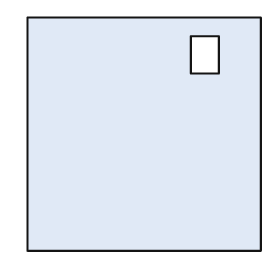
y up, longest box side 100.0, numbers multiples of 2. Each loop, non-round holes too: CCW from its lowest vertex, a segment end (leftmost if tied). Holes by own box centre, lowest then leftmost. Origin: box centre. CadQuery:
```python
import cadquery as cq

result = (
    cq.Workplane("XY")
    .moveTo(-50.0, -50.0)
    .lineTo(50.0, -50.0)
    .lineTo(50.0, 50.0)
    .lineTo(-50.0, 50.0)
    .close()
    .moveTo(20.0, 26.0)
    .lineTo(32.0, 26.0)
    .lineTo(32.0, 42.0)
    .lineTo(20.0, 42.0)
    .close()
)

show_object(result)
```